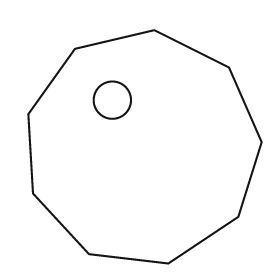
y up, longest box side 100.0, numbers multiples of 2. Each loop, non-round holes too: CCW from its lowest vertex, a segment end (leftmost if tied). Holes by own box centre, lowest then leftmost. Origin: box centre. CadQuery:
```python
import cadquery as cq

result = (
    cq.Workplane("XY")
    .moveTo(10.0, -50.0)
    .lineTo(40.0, -30.0)
    .lineTo(50.0, 2.0)
    .lineTo(36.0, 34.0)
    .lineTo(4.0, 50.0)
    .lineTo(-30.0, 42.0)
    .lineTo(-50.0, 14.0)
    .lineTo(-48.0, -20.0)
    .lineTo(-24.0, -46.0)
    .close()
    .moveTo(-14.0, 20.0)
    .circle(8.0)
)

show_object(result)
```